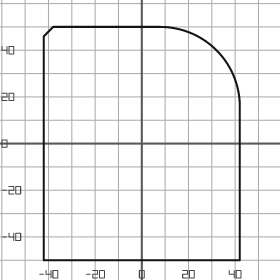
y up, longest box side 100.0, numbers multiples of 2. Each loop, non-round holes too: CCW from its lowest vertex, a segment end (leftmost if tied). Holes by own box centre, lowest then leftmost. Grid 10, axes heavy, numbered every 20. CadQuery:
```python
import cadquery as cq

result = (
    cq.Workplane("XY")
    .moveTo(-42.0, -50.0)
    .lineTo(42.0, -50.0)
    .lineTo(42.0, 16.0)
    .threePointArc((32.0, 40.0), (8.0, 50.0))
    .lineTo(-38.0, 50.0)
    .lineTo(-42.0, 46.0)
    .close()
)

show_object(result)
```